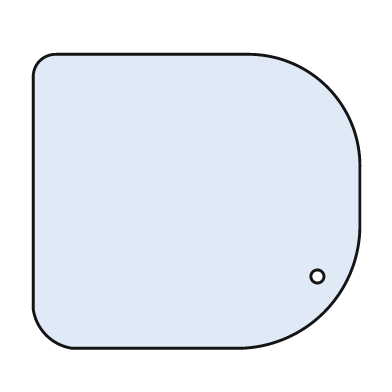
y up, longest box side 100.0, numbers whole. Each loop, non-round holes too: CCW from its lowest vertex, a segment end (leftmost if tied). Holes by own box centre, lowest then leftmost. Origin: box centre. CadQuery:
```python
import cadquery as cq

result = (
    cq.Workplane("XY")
    .moveTo(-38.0, -45.0)
    .lineTo(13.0, -45.0)
    .threePointArc((39.0, -34.0), (50.0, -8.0))
    .lineTo(50.0, 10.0)
    .threePointArc((40.0, 35.0), (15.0, 45.0))
    .lineTo(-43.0, 45.0)
    .threePointArc((-48.0, 43.0), (-50.0, 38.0))
    .lineTo(-50.0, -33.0)
    .threePointArc((-46.0, -41.0), (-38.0, -45.0))
    .close()
    .moveTo(37.0, -23.0)
    .circle(2.0)
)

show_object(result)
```